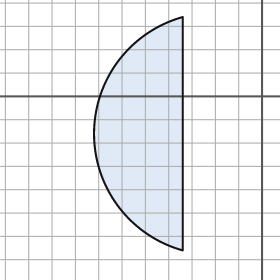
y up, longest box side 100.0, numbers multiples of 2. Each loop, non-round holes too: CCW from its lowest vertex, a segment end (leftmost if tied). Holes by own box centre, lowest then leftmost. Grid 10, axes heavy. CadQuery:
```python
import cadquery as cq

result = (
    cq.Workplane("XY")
    .moveTo(-34.0, -66.0)
    .lineTo(-34.0, 34.0)
    .threePointArc((-72.0, -16.0), (-34.0, -66.0))
    .close()
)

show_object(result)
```